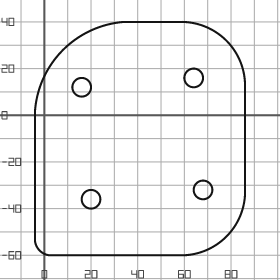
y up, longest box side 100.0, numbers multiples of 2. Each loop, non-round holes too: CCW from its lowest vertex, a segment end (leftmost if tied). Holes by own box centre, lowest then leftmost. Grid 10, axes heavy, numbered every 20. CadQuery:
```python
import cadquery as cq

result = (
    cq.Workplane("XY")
    .moveTo(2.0, -60.0)
    .lineTo(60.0, -60.0)
    .threePointArc((78.0, -52.0), (86.0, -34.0))
    .lineTo(86.0, 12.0)
    .threePointArc((78.0, 32.0), (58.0, 40.0))
    .lineTo(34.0, 40.0)
    .threePointArc((8.0, 28.0), (-4.0, 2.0))
    .lineTo(-4.0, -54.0)
    .threePointArc((-2.0, -58.0), (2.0, -60.0))
    .close()
    .moveTo(20.0, -36.0)
    .circle(4.0)
    .moveTo(68.0, -32.0)
    .circle(4.0)
    .moveTo(16.0, 12.0)
    .circle(4.0)
    .moveTo(64.0, 16.0)
    .circle(4.0)
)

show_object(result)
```